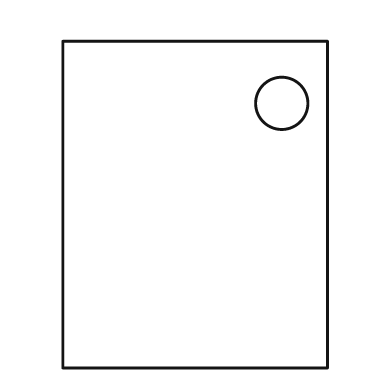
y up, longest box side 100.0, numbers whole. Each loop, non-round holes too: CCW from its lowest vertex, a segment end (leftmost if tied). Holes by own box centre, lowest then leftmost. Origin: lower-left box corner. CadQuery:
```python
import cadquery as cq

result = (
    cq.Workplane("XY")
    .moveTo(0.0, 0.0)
    .lineTo(81.0, 0.0)
    .lineTo(81.0, 100.0)
    .lineTo(0.0, 100.0)
    .close()
    .moveTo(67.0, 81.0)
    .circle(8.0)
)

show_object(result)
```